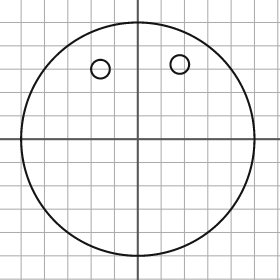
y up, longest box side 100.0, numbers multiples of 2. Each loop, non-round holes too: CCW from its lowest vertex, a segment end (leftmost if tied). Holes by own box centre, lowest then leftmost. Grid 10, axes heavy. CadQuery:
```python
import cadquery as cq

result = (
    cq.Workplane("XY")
    .moveTo(0.0, 0.0)
    .circle(50.0)
    .moveTo(-16.0, 30.0)
    .circle(4.0)
    .moveTo(18.0, 32.0)
    .circle(4.0)
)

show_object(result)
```